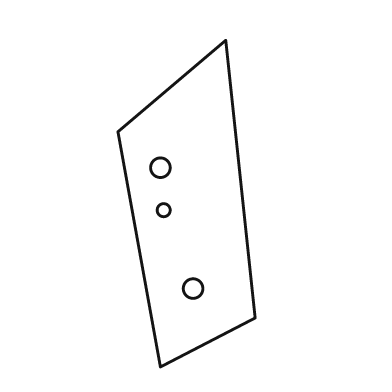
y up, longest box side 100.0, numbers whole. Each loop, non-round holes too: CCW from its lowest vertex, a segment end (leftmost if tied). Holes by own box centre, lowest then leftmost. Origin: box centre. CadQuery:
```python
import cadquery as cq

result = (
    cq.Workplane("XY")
    .moveTo(-8.0, -50.0)
    .lineTo(21.0, -35.0)
    .lineTo(12.0, 50.0)
    .lineTo(-21.0, 22.0)
    .close()
    .moveTo(2.0, -26.0)
    .circle(3.0)
    .moveTo(-7.0, -2.0)
    .circle(2.0)
    .moveTo(-8.0, 11.0)
    .circle(3.0)
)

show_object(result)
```